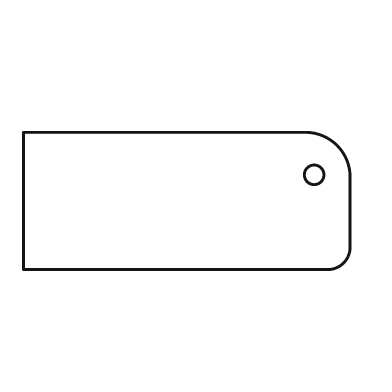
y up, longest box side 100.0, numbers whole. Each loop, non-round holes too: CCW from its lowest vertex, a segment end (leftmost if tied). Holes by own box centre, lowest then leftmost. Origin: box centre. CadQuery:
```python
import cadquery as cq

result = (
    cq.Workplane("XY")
    .moveTo(-50.0, -21.0)
    .lineTo(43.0, -21.0)
    .threePointArc((48.0, -19.0), (50.0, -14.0))
    .lineTo(50.0, 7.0)
    .threePointArc((46.0, 17.0), (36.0, 21.0))
    .lineTo(-50.0, 21.0)
    .close()
    .moveTo(39.0, 8.0)
    .circle(3.0)
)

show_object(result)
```